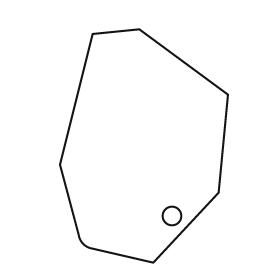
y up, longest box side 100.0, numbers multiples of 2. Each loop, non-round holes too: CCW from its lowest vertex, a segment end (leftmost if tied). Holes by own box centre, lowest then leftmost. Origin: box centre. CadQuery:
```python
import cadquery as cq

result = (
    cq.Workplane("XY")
    .moveTo(4.0, -50.0)
    .lineTo(32.0, -20.0)
    .lineTo(36.0, 22.0)
    .lineTo(-2.0, 50.0)
    .lineTo(-22.0, 48.0)
    .lineTo(-36.0, -8.0)
    .lineTo(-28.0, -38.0)
    .threePointArc((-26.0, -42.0), (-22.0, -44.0))
    .close()
    .moveTo(12.0, -30.0)
    .circle(4.0)
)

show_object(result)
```